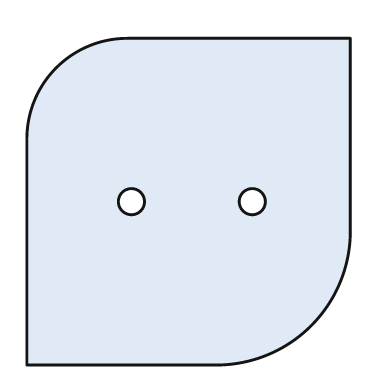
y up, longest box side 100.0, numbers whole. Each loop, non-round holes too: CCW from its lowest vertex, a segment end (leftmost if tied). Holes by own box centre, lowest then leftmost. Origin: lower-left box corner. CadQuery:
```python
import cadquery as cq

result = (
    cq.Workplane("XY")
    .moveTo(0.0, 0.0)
    .lineTo(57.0, 0.0)
    .threePointArc((87.0, 12.0), (99.0, 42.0))
    .lineTo(99.0, 100.0)
    .lineTo(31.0, 100.0)
    .threePointArc((9.0, 91.0), (0.0, 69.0))
    .close()
    .moveTo(32.0, 50.0)
    .circle(4.0)
    .moveTo(69.0, 50.0)
    .circle(4.0)
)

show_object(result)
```